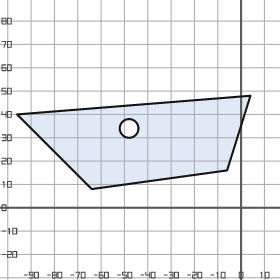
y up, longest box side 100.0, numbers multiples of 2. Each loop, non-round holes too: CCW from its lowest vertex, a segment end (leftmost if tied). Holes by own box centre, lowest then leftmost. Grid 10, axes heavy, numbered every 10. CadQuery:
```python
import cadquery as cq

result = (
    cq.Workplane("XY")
    .moveTo(-64.0, 8.0)
    .lineTo(-6.0, 16.0)
    .lineTo(4.0, 48.0)
    .lineTo(-96.0, 40.0)
    .close()
    .moveTo(-48.0, 34.0)
    .circle(4.0)
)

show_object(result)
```